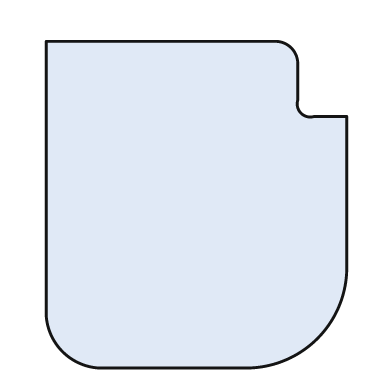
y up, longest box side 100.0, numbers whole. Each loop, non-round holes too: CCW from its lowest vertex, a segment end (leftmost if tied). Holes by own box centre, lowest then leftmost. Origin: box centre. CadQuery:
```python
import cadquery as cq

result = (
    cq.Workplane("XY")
    .moveTo(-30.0, -50.0)
    .lineTo(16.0, -50.0)
    .threePointArc((37.0, -41.0), (46.0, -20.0))
    .lineTo(46.0, 27.0)
    .lineTo(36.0, 27.0)
    .threePointArc((32.0, 28.0), (31.0, 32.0))
    .lineTo(31.0, 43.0)
    .threePointArc((29.0, 48.0), (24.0, 50.0))
    .lineTo(-46.0, 50.0)
    .lineTo(-46.0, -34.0)
    .threePointArc((-41.0, -45.0), (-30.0, -50.0))
    .close()
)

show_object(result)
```